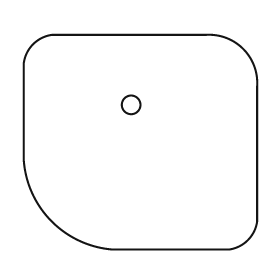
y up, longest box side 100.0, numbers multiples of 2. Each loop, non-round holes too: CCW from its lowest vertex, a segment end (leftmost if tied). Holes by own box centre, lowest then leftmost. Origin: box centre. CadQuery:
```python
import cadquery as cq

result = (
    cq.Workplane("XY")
    .moveTo(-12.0, -46.0)
    .lineTo(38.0, -46.0)
    .threePointArc((46.0, -42.0), (50.0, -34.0))
    .lineTo(50.0, 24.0)
    .threePointArc((44.0, 40.0), (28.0, 46.0))
    .lineTo(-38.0, 46.0)
    .threePointArc((-46.0, 42.0), (-50.0, 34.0))
    .lineTo(-50.0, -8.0)
    .threePointArc((-38.0, -34.0), (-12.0, -46.0))
    .close()
    .moveTo(-4.0, 16.0)
    .circle(4.0)
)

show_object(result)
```